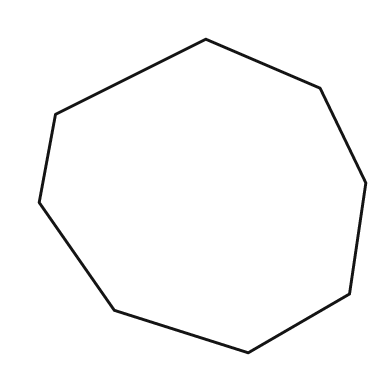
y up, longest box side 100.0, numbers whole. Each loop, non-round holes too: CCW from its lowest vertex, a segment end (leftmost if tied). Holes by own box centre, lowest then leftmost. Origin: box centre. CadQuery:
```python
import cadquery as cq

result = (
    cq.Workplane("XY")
    .moveTo(14.0, -48.0)
    .lineTo(45.0, -30.0)
    .lineTo(50.0, 4.0)
    .lineTo(36.0, 33.0)
    .lineTo(1.0, 48.0)
    .lineTo(-45.0, 25.0)
    .lineTo(-50.0, -2.0)
    .lineTo(-27.0, -35.0)
    .close()
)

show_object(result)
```